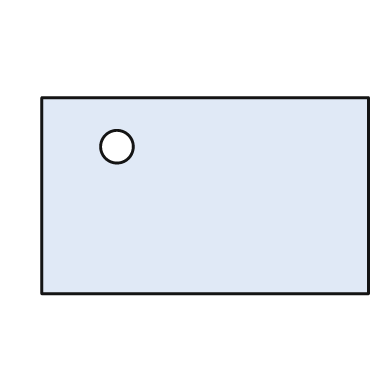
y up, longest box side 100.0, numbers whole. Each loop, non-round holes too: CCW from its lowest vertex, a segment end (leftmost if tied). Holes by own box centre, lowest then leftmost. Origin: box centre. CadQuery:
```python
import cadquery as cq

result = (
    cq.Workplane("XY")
    .moveTo(-50.0, -30.0)
    .lineTo(50.0, -30.0)
    .lineTo(50.0, 30.0)
    .lineTo(-50.0, 30.0)
    .close()
    .moveTo(-27.0, 15.0)
    .circle(5.0)
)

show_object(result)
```